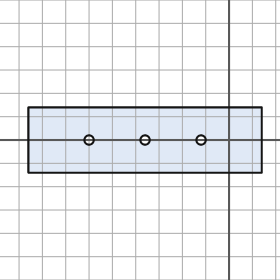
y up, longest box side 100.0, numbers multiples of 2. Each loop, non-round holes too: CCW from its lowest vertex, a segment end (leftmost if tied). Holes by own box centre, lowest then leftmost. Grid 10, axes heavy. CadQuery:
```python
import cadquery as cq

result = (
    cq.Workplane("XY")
    .moveTo(-86.0, -14.0)
    .lineTo(14.0, -14.0)
    .lineTo(14.0, 14.0)
    .lineTo(-86.0, 14.0)
    .close()
    .moveTo(-60.0, 0.0)
    .circle(2.0)
    .moveTo(-36.0, 0.0)
    .circle(2.0)
    .moveTo(-12.0, 0.0)
    .circle(2.0)
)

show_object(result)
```